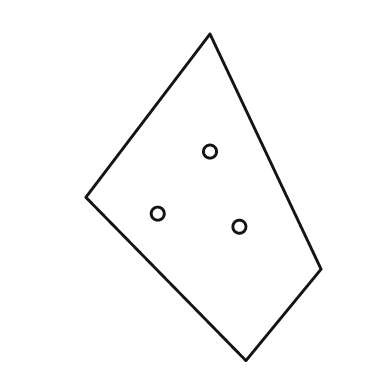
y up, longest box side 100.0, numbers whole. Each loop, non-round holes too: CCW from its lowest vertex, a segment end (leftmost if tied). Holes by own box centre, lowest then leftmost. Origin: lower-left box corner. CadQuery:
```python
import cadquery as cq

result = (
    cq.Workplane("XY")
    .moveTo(49.0, 0.0)
    .lineTo(72.0, 28.0)
    .lineTo(38.0, 100.0)
    .lineTo(0.0, 50.0)
    .close()
    .moveTo(47.0, 41.0)
    .circle(2.0)
    .moveTo(22.0, 45.0)
    .circle(2.0)
    .moveTo(38.0, 64.0)
    .circle(2.0)
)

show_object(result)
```